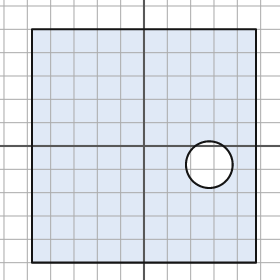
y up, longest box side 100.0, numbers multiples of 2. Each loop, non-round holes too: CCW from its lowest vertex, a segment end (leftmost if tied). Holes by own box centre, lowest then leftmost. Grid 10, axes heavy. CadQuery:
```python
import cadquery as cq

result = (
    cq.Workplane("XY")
    .moveTo(-48.0, -50.0)
    .lineTo(48.0, -50.0)
    .lineTo(48.0, 50.0)
    .lineTo(-48.0, 50.0)
    .close()
    .moveTo(28.0, -8.0)
    .circle(10.0)
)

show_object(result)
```